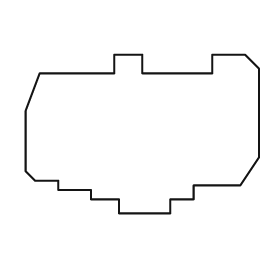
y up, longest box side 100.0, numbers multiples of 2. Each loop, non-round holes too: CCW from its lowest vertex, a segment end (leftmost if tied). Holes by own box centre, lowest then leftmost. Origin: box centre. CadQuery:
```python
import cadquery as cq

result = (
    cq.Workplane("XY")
    .moveTo(-10.0, -34.0)
    .lineTo(12.0, -34.0)
    .lineTo(12.0, -28.0)
    .lineTo(22.0, -28.0)
    .lineTo(22.0, -22.0)
    .lineTo(42.0, -22.0)
    .lineTo(50.0, -10.0)
    .lineTo(50.0, 28.0)
    .lineTo(44.0, 34.0)
    .lineTo(30.0, 34.0)
    .lineTo(30.0, 26.0)
    .lineTo(0.0, 26.0)
    .lineTo(0.0, 34.0)
    .lineTo(-12.0, 34.0)
    .lineTo(-12.0, 26.0)
    .lineTo(-44.0, 26.0)
    .lineTo(-50.0, 10.0)
    .lineTo(-50.0, -16.0)
    .lineTo(-46.0, -20.0)
    .lineTo(-36.0, -20.0)
    .lineTo(-36.0, -24.0)
    .lineTo(-22.0, -24.0)
    .lineTo(-22.0, -28.0)
    .lineTo(-10.0, -28.0)
    .close()
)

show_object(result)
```